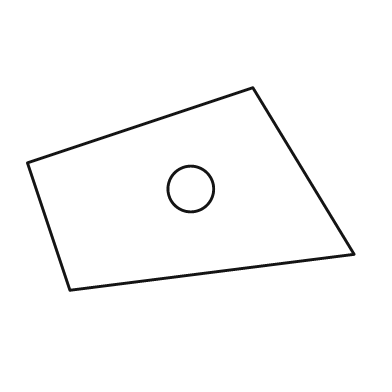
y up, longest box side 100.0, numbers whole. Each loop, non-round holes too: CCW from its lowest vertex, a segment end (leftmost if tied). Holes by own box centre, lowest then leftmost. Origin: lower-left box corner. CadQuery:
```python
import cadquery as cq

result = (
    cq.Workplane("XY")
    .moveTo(13.0, 0.0)
    .lineTo(100.0, 11.0)
    .lineTo(69.0, 62.0)
    .lineTo(0.0, 39.0)
    .close()
    .moveTo(50.0, 31.0)
    .circle(7.0)
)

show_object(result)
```